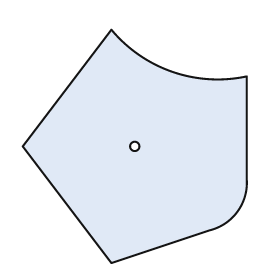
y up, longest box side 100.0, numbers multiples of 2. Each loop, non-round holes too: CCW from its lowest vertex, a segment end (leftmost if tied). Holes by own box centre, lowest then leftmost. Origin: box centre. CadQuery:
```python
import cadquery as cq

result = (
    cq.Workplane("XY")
    .moveTo(-10.0, -50.0)
    .lineTo(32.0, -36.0)
    .threePointArc((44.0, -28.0), (48.0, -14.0))
    .lineTo(48.0, 30.0)
    .threePointArc((16.0, 32.0), (-10.0, 50.0))
    .lineTo(-48.0, 0.0)
    .close()
    .moveTo(0.0, 0.0)
    .circle(2.0)
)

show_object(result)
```